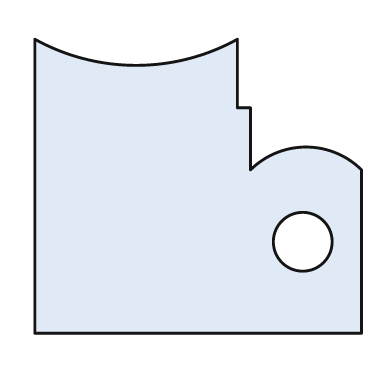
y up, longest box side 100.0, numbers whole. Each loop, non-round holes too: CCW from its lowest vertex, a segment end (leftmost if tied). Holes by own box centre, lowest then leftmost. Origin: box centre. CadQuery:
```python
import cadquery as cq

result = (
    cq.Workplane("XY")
    .moveTo(-50.0, -45.0)
    .lineTo(50.0, -45.0)
    .lineTo(50.0, 5.0)
    .threePointArc((33.0, 12.0), (16.0, 5.0))
    .lineTo(16.0, 24.0)
    .lineTo(12.0, 24.0)
    .lineTo(12.0, 45.0)
    .threePointArc((-19.0, 37.0), (-50.0, 45.0))
    .close()
    .moveTo(32.0, -17.0)
    .circle(9.0)
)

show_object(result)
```